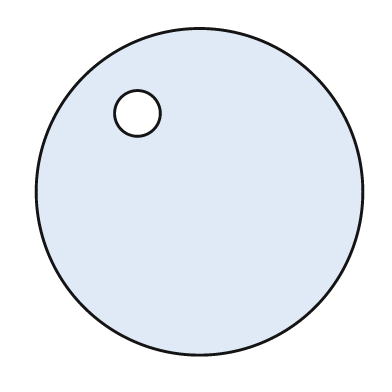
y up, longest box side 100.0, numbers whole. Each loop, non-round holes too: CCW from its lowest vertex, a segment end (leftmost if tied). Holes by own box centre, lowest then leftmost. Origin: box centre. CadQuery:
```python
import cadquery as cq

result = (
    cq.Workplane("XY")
    .moveTo(0.0, 0.0)
    .circle(50.0)
    .moveTo(-19.0, 24.0)
    .circle(7.0)
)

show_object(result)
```